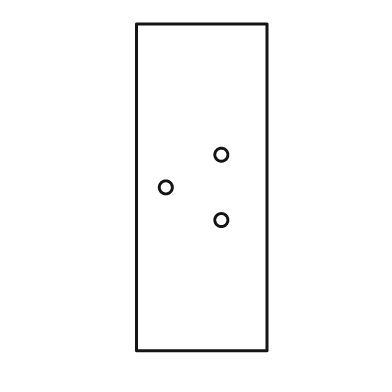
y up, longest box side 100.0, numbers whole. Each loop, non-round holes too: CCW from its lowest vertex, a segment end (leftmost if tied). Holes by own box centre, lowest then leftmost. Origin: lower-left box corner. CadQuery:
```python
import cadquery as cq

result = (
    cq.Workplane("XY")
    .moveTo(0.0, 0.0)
    .lineTo(40.0, 0.0)
    .lineTo(40.0, 100.0)
    .lineTo(0.0, 100.0)
    .close()
    .moveTo(26.0, 40.0)
    .circle(2.0)
    .moveTo(9.0, 50.0)
    .circle(2.0)
    .moveTo(26.0, 60.0)
    .circle(2.0)
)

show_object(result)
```